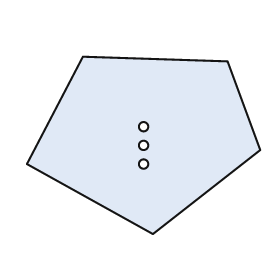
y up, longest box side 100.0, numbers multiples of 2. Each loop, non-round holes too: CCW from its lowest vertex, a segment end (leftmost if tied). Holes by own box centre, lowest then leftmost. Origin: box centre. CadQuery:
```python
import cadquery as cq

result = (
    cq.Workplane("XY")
    .moveTo(4.0, -38.0)
    .lineTo(50.0, -2.0)
    .lineTo(36.0, 36.0)
    .lineTo(-26.0, 38.0)
    .lineTo(-50.0, -8.0)
    .close()
    .moveTo(0.0, -8.0)
    .circle(2.0)
    .moveTo(0.0, 0.0)
    .circle(2.0)
    .moveTo(0.0, 8.0)
    .circle(2.0)
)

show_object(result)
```